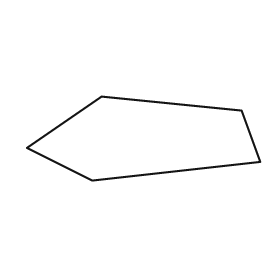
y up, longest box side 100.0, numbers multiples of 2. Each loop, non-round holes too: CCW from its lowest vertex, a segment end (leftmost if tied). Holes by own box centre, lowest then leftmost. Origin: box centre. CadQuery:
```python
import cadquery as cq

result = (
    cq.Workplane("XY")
    .moveTo(-22.0, -18.0)
    .lineTo(50.0, -10.0)
    .lineTo(42.0, 12.0)
    .lineTo(-18.0, 18.0)
    .lineTo(-50.0, -4.0)
    .close()
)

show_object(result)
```